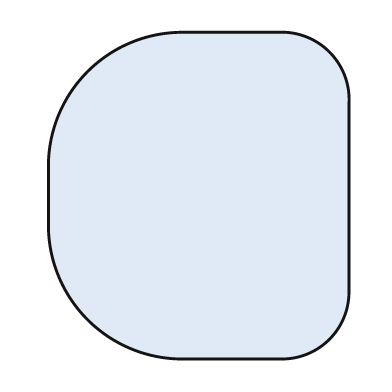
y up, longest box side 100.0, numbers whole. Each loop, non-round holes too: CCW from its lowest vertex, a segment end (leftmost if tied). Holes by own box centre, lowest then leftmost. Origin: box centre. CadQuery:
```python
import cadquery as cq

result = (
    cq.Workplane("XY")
    .moveTo(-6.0, -50.0)
    .lineTo(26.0, -50.0)
    .threePointArc((40.0, -44.0), (46.0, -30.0))
    .lineTo(46.0, 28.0)
    .threePointArc((40.0, 44.0), (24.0, 50.0))
    .lineTo(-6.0, 50.0)
    .threePointArc((-34.0, 38.0), (-46.0, 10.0))
    .lineTo(-46.0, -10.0)
    .threePointArc((-34.0, -38.0), (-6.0, -50.0))
    .close()
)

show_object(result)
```